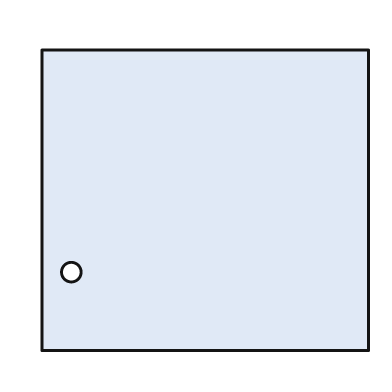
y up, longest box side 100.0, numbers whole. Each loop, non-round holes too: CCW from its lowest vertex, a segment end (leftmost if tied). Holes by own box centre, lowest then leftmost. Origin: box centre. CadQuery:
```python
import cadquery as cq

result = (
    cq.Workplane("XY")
    .moveTo(-50.0, -46.0)
    .lineTo(50.0, -46.0)
    .lineTo(50.0, 46.0)
    .lineTo(-50.0, 46.0)
    .close()
    .moveTo(-41.0, -22.0)
    .circle(3.0)
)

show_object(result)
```